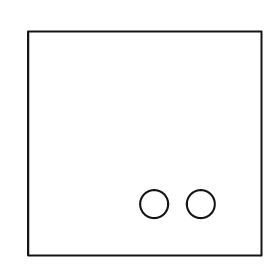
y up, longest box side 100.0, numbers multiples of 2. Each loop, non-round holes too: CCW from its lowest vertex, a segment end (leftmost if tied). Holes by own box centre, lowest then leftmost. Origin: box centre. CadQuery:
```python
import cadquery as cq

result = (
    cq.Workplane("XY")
    .moveTo(-50.0, -48.0)
    .lineTo(50.0, -48.0)
    .lineTo(50.0, 48.0)
    .lineTo(-50.0, 48.0)
    .close()
    .moveTo(4.0, -26.0)
    .circle(6.0)
    .moveTo(24.0, -26.0)
    .circle(6.0)
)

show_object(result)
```